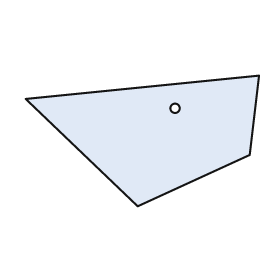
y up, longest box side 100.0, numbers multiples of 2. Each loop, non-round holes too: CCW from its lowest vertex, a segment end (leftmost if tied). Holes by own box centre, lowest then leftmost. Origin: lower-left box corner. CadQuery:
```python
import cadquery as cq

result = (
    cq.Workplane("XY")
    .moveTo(48.0, 0.0)
    .lineTo(96.0, 22.0)
    .lineTo(100.0, 56.0)
    .lineTo(0.0, 46.0)
    .close()
    .moveTo(64.0, 42.0)
    .circle(2.0)
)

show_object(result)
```